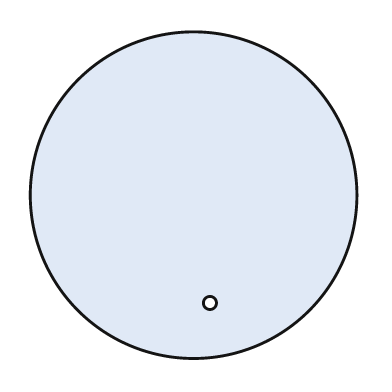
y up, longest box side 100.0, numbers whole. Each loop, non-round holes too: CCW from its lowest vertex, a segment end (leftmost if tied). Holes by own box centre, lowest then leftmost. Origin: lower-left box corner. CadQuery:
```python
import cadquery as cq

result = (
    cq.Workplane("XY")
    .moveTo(50.0, 50.0)
    .circle(50.0)
    .moveTo(55.0, 17.0)
    .circle(2.0)
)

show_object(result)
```